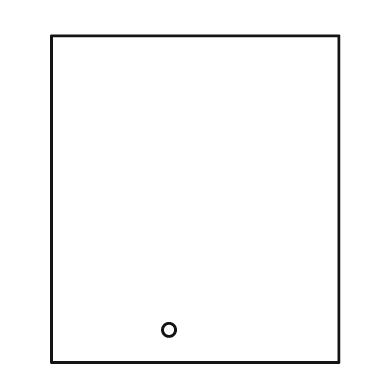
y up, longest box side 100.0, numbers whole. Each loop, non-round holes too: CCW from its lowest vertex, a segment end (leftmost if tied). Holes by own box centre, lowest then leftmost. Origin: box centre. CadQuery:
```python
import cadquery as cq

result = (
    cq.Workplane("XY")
    .moveTo(-44.0, -50.0)
    .lineTo(44.0, -50.0)
    .lineTo(44.0, 50.0)
    .lineTo(-44.0, 50.0)
    .close()
    .moveTo(-8.0, -40.0)
    .circle(2.0)
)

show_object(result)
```